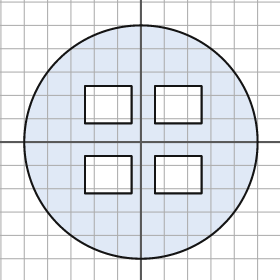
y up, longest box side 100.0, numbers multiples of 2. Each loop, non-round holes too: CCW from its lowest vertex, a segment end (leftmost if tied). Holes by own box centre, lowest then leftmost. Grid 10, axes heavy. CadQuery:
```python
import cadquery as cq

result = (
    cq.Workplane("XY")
    .moveTo(0.0, 0.0)
    .circle(50.0)
    .moveTo(-24.0, -22.0)
    .lineTo(-4.0, -22.0)
    .lineTo(-4.0, -6.0)
    .lineTo(-24.0, -6.0)
    .close()
    .moveTo(6.0, -22.0)
    .lineTo(26.0, -22.0)
    .lineTo(26.0, -6.0)
    .lineTo(6.0, -6.0)
    .close()
    .moveTo(-24.0, 8.0)
    .lineTo(-4.0, 8.0)
    .lineTo(-4.0, 24.0)
    .lineTo(-24.0, 24.0)
    .close()
    .moveTo(6.0, 8.0)
    .lineTo(26.0, 8.0)
    .lineTo(26.0, 24.0)
    .lineTo(6.0, 24.0)
    .close()
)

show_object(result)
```